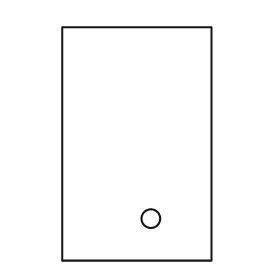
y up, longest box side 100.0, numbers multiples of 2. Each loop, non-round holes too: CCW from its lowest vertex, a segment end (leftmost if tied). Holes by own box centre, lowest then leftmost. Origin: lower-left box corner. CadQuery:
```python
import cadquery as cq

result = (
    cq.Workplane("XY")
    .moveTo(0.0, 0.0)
    .lineTo(64.0, 0.0)
    .lineTo(64.0, 100.0)
    .lineTo(0.0, 100.0)
    .close()
    .moveTo(38.0, 18.0)
    .circle(4.0)
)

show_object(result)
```